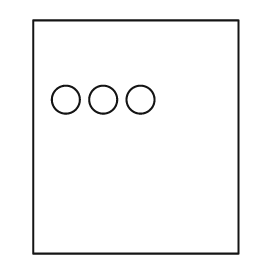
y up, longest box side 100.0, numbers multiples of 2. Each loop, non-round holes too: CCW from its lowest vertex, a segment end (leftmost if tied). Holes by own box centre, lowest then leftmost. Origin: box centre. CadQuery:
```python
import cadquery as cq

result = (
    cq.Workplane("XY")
    .moveTo(-44.0, -50.0)
    .lineTo(44.0, -50.0)
    .lineTo(44.0, 50.0)
    .lineTo(-44.0, 50.0)
    .close()
    .moveTo(-30.0, 16.0)
    .circle(6.0)
    .moveTo(-14.0, 16.0)
    .circle(6.0)
    .moveTo(2.0, 16.0)
    .circle(6.0)
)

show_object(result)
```